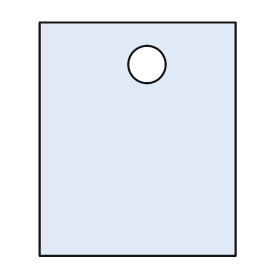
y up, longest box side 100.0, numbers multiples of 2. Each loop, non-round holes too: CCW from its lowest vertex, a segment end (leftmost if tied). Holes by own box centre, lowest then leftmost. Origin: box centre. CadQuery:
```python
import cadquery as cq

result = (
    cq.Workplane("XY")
    .moveTo(-42.0, -50.0)
    .lineTo(42.0, -50.0)
    .lineTo(42.0, 50.0)
    .lineTo(-42.0, 50.0)
    .close()
    .moveTo(4.0, 32.0)
    .circle(8.0)
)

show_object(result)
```